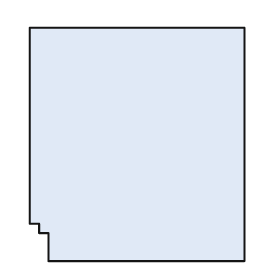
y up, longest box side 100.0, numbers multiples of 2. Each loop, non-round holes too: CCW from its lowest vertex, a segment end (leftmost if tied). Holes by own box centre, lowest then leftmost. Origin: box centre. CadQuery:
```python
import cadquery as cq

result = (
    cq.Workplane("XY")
    .moveTo(-38.0, -50.0)
    .lineTo(46.0, -50.0)
    .lineTo(46.0, 50.0)
    .lineTo(-46.0, 50.0)
    .lineTo(-46.0, -34.0)
    .lineTo(-42.0, -34.0)
    .lineTo(-42.0, -38.0)
    .lineTo(-38.0, -38.0)
    .close()
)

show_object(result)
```